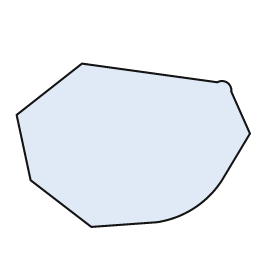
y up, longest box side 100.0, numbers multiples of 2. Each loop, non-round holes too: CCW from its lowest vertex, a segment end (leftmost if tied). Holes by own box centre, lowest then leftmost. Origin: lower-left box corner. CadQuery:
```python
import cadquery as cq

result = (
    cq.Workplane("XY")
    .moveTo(32.0, 0.0)
    .lineTo(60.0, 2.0)
    .threePointArc((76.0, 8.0), (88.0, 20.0))
    .lineTo(100.0, 40.0)
    .lineTo(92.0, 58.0)
    .threePointArc((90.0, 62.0), (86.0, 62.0))
    .lineTo(28.0, 70.0)
    .lineTo(0.0, 48.0)
    .lineTo(6.0, 20.0)
    .close()
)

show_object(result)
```